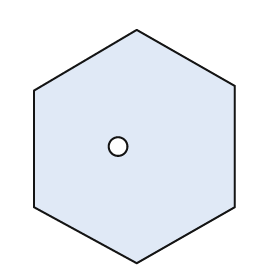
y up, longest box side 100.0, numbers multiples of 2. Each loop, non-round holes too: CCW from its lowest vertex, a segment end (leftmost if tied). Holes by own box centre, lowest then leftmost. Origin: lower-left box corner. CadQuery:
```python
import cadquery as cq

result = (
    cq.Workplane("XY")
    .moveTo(44.0, 0.0)
    .lineTo(86.0, 24.0)
    .lineTo(86.0, 76.0)
    .lineTo(44.0, 100.0)
    .lineTo(0.0, 74.0)
    .lineTo(0.0, 24.0)
    .close()
    .moveTo(36.0, 50.0)
    .circle(4.0)
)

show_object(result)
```